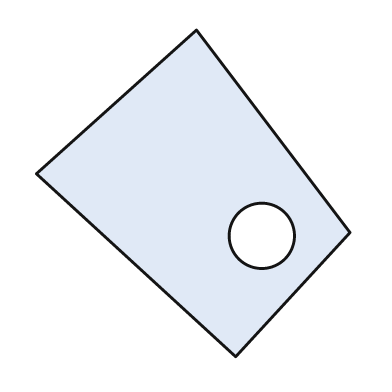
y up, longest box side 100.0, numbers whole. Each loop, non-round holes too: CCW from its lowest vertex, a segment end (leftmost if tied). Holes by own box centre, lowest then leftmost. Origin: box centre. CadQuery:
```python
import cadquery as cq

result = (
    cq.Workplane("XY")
    .moveTo(13.0, -50.0)
    .lineTo(48.0, -12.0)
    .lineTo(1.0, 50.0)
    .lineTo(-48.0, 6.0)
    .close()
    .moveTo(21.0, -13.0)
    .circle(10.0)
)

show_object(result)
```